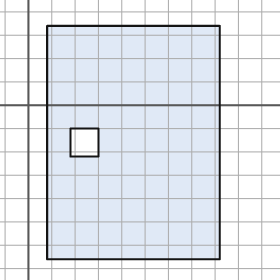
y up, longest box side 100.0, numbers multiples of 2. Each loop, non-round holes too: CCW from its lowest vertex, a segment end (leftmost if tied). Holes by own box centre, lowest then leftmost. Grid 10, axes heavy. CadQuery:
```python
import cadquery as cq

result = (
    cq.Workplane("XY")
    .moveTo(8.0, -66.0)
    .lineTo(82.0, -66.0)
    .lineTo(82.0, 34.0)
    .lineTo(8.0, 34.0)
    .close()
    .moveTo(18.0, -22.0)
    .lineTo(30.0, -22.0)
    .lineTo(30.0, -10.0)
    .lineTo(18.0, -10.0)
    .close()
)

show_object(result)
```